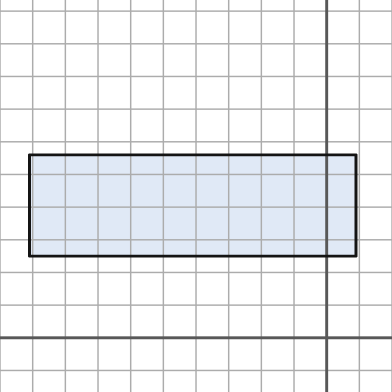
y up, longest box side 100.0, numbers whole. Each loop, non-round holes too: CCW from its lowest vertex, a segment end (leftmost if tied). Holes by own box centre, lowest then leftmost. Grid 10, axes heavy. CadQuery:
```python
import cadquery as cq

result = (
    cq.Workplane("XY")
    .moveTo(-91.0, 25.0)
    .lineTo(9.0, 25.0)
    .lineTo(9.0, 56.0)
    .lineTo(-91.0, 56.0)
    .close()
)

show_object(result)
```